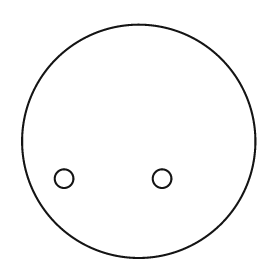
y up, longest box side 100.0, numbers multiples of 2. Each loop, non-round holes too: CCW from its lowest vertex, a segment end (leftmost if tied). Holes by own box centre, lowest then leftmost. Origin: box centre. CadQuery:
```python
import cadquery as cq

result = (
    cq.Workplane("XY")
    .moveTo(0.0, 0.0)
    .circle(50.0)
    .moveTo(-32.0, -16.0)
    .circle(4.0)
    .moveTo(10.0, -16.0)
    .circle(4.0)
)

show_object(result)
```